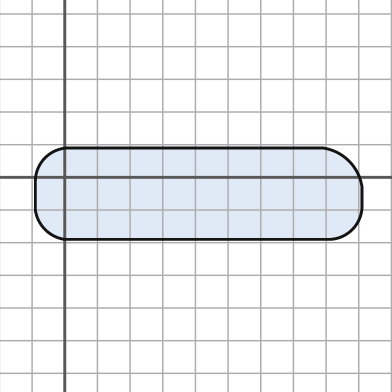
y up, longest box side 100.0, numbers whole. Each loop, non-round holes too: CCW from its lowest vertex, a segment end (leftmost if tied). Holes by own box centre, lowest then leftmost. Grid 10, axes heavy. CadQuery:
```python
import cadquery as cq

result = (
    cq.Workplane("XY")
    .moveTo(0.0, -19.0)
    .lineTo(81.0, -19.0)
    .threePointArc((88.0, -16.0), (91.0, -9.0))
    .lineTo(91.0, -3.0)
    .threePointArc((87.0, 5.0), (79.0, 9.0))
    .lineTo(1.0, 9.0)
    .threePointArc((-6.0, 6.0), (-9.0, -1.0))
    .lineTo(-9.0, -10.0)
    .threePointArc((-6.0, -16.0), (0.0, -19.0))
    .close()
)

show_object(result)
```